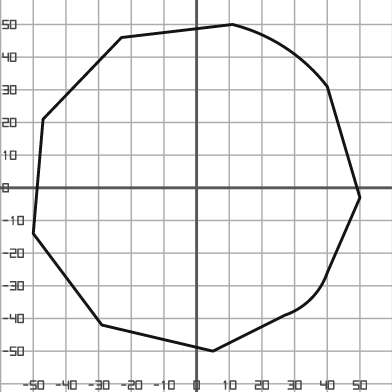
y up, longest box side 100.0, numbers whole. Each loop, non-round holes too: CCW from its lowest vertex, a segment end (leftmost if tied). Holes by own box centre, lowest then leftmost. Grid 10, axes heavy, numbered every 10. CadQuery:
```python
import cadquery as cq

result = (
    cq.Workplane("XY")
    .moveTo(5.0, -50.0)
    .lineTo(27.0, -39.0)
    .threePointArc((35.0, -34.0), (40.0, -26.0))
    .lineTo(50.0, -3.0)
    .lineTo(40.0, 31.0)
    .threePointArc((27.0, 43.0), (11.0, 50.0))
    .lineTo(-23.0, 46.0)
    .lineTo(-47.0, 21.0)
    .lineTo(-50.0, -14.0)
    .lineTo(-29.0, -42.0)
    .close()
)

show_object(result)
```